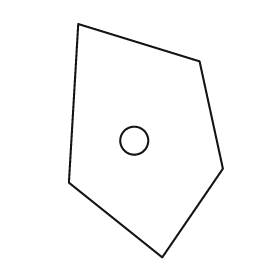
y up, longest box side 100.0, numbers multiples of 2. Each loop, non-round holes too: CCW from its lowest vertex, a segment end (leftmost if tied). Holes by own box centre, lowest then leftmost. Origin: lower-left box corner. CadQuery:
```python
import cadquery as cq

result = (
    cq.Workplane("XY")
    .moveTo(40.0, 0.0)
    .lineTo(66.0, 38.0)
    .lineTo(56.0, 84.0)
    .lineTo(4.0, 100.0)
    .lineTo(0.0, 32.0)
    .close()
    .moveTo(28.0, 50.0)
    .circle(6.0)
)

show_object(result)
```